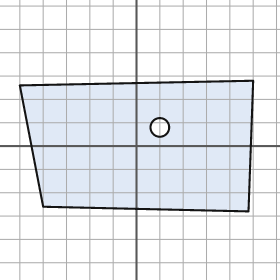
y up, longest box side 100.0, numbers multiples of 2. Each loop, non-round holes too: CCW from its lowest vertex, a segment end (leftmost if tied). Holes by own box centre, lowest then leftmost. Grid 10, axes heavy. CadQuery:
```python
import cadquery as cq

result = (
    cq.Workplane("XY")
    .moveTo(48.0, -28.0)
    .lineTo(50.0, 28.0)
    .lineTo(-50.0, 26.0)
    .lineTo(-40.0, -26.0)
    .close()
    .moveTo(10.0, 8.0)
    .circle(4.0)
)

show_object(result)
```